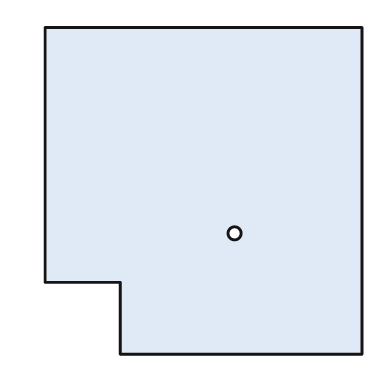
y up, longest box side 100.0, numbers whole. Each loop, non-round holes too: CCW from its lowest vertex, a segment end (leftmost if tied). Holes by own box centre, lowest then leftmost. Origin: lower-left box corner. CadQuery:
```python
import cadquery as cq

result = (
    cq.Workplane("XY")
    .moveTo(23.0, 0.0)
    .lineTo(97.0, 0.0)
    .lineTo(97.0, 100.0)
    .lineTo(0.0, 100.0)
    .lineTo(0.0, 22.0)
    .lineTo(23.0, 22.0)
    .close()
    .moveTo(58.0, 37.0)
    .circle(2.0)
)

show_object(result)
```